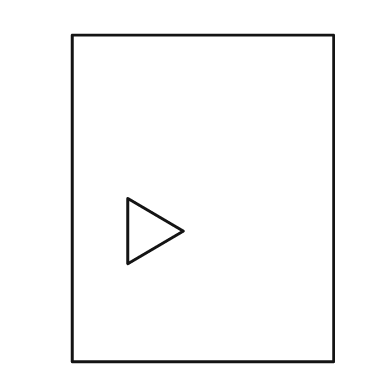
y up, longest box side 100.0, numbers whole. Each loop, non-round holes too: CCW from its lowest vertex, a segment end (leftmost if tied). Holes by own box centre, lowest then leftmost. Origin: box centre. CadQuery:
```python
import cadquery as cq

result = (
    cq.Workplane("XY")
    .moveTo(-40.0, -50.0)
    .lineTo(40.0, -50.0)
    .lineTo(40.0, 50.0)
    .lineTo(-40.0, 50.0)
    .close()
    .moveTo(-23.0, -20.0)
    .lineTo(-6.0, -10.0)
    .lineTo(-23.0, 0.0)
    .close()
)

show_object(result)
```